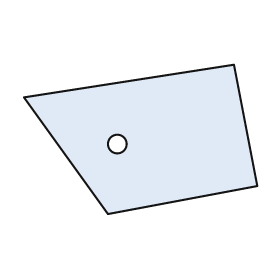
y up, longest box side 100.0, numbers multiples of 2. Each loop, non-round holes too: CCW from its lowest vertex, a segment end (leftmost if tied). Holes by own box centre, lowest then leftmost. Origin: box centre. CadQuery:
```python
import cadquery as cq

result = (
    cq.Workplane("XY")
    .moveTo(-14.0, -32.0)
    .lineTo(50.0, -20.0)
    .lineTo(40.0, 32.0)
    .lineTo(-50.0, 18.0)
    .close()
    .moveTo(-10.0, -2.0)
    .circle(4.0)
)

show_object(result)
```